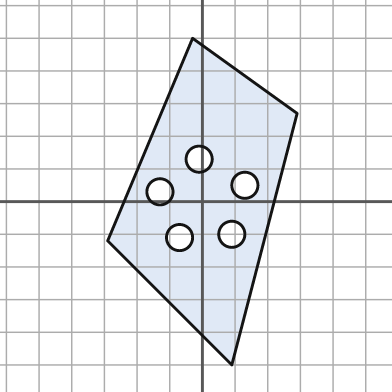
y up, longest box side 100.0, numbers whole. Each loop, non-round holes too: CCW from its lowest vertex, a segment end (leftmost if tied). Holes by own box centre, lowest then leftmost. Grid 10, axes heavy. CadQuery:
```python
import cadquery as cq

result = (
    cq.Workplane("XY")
    .moveTo(9.0, -50.0)
    .lineTo(29.0, 27.0)
    .lineTo(-3.0, 50.0)
    .lineTo(-29.0, -12.0)
    .close()
    .moveTo(-7.0, -11.0)
    .circle(4.0)
    .moveTo(9.0, -10.0)
    .circle(4.0)
    .moveTo(-13.0, 3.0)
    .circle(4.0)
    .moveTo(13.0, 5.0)
    .circle(4.0)
    .moveTo(-1.0, 13.0)
    .circle(4.0)
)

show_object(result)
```